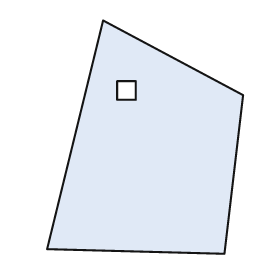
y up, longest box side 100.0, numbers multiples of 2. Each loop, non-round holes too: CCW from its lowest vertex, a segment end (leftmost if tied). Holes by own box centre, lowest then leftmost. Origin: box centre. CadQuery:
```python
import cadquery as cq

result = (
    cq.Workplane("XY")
    .moveTo(34.0, -50.0)
    .lineTo(42.0, 18.0)
    .lineTo(-18.0, 50.0)
    .lineTo(-42.0, -48.0)
    .close()
    .moveTo(-12.0, 16.0)
    .lineTo(-4.0, 16.0)
    .lineTo(-4.0, 24.0)
    .lineTo(-12.0, 24.0)
    .close()
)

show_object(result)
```